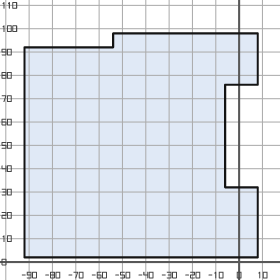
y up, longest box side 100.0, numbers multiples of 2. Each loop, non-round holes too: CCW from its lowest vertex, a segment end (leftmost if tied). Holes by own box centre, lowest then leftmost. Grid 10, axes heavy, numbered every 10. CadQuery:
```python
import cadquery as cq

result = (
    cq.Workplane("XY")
    .moveTo(-92.0, 2.0)
    .lineTo(8.0, 2.0)
    .lineTo(8.0, 32.0)
    .lineTo(-6.0, 32.0)
    .lineTo(-6.0, 76.0)
    .lineTo(8.0, 76.0)
    .lineTo(8.0, 98.0)
    .lineTo(-54.0, 98.0)
    .lineTo(-54.0, 92.0)
    .lineTo(-92.0, 92.0)
    .close()
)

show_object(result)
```